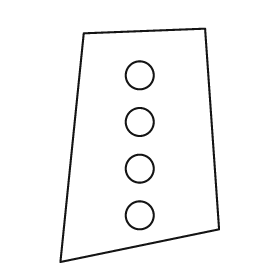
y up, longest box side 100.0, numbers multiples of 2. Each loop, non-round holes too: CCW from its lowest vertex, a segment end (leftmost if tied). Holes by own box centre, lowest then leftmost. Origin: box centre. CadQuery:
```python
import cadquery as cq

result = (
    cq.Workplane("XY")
    .moveTo(-34.0, -50.0)
    .lineTo(34.0, -36.0)
    .lineTo(28.0, 50.0)
    .lineTo(-24.0, 48.0)
    .close()
    .moveTo(0.0, -30.0)
    .circle(6.0)
    .moveTo(0.0, -10.0)
    .circle(6.0)
    .moveTo(0.0, 10.0)
    .circle(6.0)
    .moveTo(0.0, 30.0)
    .circle(6.0)
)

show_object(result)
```